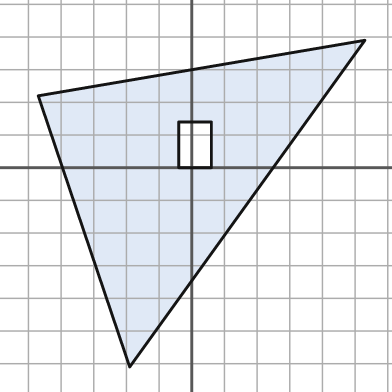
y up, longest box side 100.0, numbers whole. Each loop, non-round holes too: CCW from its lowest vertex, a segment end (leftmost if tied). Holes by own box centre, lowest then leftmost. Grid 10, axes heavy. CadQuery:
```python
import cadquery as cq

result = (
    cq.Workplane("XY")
    .moveTo(-19.0, -61.0)
    .lineTo(53.0, 39.0)
    .lineTo(-47.0, 22.0)
    .close()
    .moveTo(-4.0, 0.0)
    .lineTo(6.0, 0.0)
    .lineTo(6.0, 14.0)
    .lineTo(-4.0, 14.0)
    .close()
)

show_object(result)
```